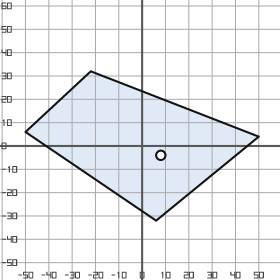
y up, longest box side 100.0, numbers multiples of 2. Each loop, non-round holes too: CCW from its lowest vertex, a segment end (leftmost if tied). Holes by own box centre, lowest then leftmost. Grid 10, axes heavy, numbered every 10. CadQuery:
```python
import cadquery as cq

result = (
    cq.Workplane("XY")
    .moveTo(6.0, -32.0)
    .lineTo(50.0, 4.0)
    .lineTo(-22.0, 32.0)
    .lineTo(-50.0, 6.0)
    .close()
    .moveTo(8.0, -4.0)
    .circle(2.0)
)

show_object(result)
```